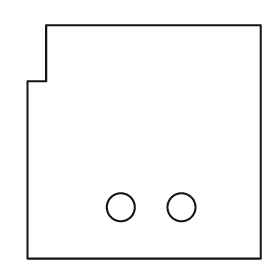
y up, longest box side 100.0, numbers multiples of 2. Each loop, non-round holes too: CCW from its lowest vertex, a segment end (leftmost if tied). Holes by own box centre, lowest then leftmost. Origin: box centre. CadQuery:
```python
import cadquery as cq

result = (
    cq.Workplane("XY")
    .moveTo(-50.0, -50.0)
    .lineTo(50.0, -50.0)
    .lineTo(50.0, 50.0)
    .lineTo(-42.0, 50.0)
    .lineTo(-42.0, 26.0)
    .lineTo(-50.0, 26.0)
    .close()
    .moveTo(-10.0, -28.0)
    .circle(6.0)
    .moveTo(16.0, -28.0)
    .circle(6.0)
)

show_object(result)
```